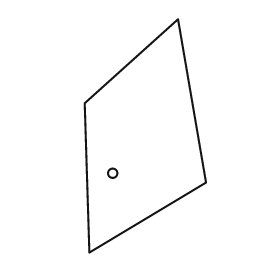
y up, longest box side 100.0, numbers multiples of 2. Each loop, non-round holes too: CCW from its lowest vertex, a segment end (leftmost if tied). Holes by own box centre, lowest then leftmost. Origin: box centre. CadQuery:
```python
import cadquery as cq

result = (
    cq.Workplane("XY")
    .moveTo(-24.0, -50.0)
    .lineTo(26.0, -20.0)
    .lineTo(14.0, 50.0)
    .lineTo(-26.0, 14.0)
    .close()
    .moveTo(-14.0, -16.0)
    .circle(2.0)
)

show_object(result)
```